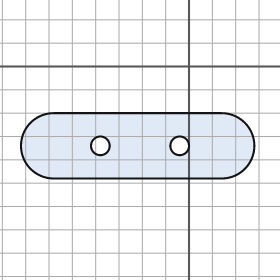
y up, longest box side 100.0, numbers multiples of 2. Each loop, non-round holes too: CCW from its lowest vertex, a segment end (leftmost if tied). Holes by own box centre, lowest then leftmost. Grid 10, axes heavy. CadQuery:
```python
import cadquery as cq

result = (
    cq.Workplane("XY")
    .moveTo(-58.0, -48.0)
    .lineTo(14.0, -48.0)
    .threePointArc((28.0, -34.0), (14.0, -20.0))
    .lineTo(-58.0, -20.0)
    .threePointArc((-72.0, -34.0), (-58.0, -48.0))
    .close()
    .moveTo(-38.0, -34.0)
    .circle(4.0)
    .moveTo(-4.0, -34.0)
    .circle(4.0)
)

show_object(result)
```